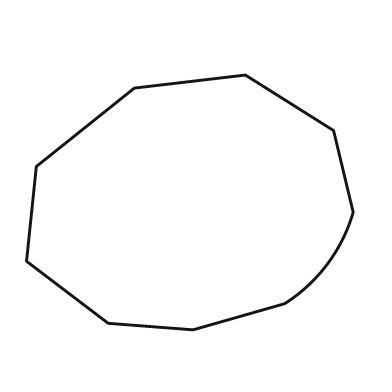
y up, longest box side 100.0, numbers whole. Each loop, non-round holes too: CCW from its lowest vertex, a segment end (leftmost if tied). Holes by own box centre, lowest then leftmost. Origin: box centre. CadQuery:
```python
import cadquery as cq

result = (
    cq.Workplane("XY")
    .moveTo(1.0, -39.0)
    .lineTo(29.0, -31.0)
    .threePointArc((42.0, -19.0), (50.0, -3.0))
    .lineTo(44.0, 22.0)
    .lineTo(17.0, 39.0)
    .lineTo(-17.0, 35.0)
    .lineTo(-47.0, 11.0)
    .lineTo(-50.0, -18.0)
    .lineTo(-25.0, -37.0)
    .close()
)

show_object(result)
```